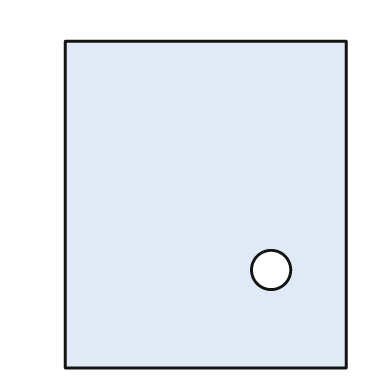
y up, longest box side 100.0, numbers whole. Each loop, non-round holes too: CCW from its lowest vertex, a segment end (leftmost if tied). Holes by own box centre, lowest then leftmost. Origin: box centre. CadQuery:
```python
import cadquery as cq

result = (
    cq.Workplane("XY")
    .moveTo(-43.0, -50.0)
    .lineTo(43.0, -50.0)
    .lineTo(43.0, 50.0)
    .lineTo(-43.0, 50.0)
    .close()
    .moveTo(20.0, -20.0)
    .circle(6.0)
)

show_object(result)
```